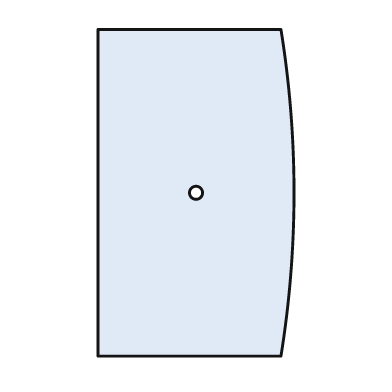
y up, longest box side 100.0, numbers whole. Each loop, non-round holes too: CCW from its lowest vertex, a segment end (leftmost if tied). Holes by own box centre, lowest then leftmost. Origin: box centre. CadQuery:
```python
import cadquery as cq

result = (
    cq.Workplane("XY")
    .moveTo(-30.0, -50.0)
    .lineTo(26.0, -50.0)
    .threePointArc((30.0, 0.0), (26.0, 50.0))
    .lineTo(-30.0, 50.0)
    .close()
    .moveTo(0.0, 0.0)
    .circle(2.0)
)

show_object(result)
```